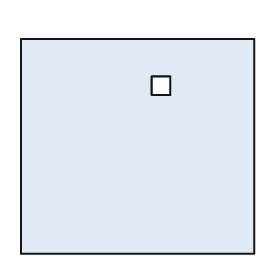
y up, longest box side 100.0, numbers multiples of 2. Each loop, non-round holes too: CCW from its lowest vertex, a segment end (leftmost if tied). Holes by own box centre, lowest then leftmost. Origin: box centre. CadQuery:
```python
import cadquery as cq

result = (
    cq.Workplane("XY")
    .moveTo(-50.0, -46.0)
    .lineTo(50.0, -46.0)
    .lineTo(50.0, 46.0)
    .lineTo(-50.0, 46.0)
    .close()
    .moveTo(6.0, 22.0)
    .lineTo(14.0, 22.0)
    .lineTo(14.0, 30.0)
    .lineTo(6.0, 30.0)
    .close()
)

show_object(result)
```